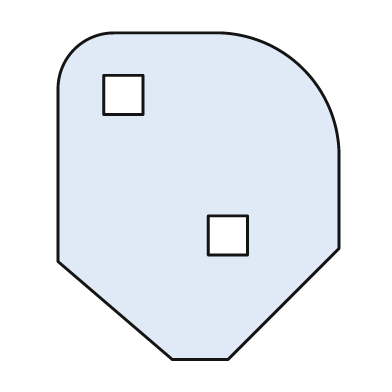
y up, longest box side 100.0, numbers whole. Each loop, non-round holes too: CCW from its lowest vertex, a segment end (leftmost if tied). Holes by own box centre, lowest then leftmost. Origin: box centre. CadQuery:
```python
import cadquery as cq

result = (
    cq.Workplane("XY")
    .moveTo(-8.0, -50.0)
    .lineTo(9.0, -50.0)
    .lineTo(43.0, -16.0)
    .lineTo(43.0, 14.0)
    .threePointArc((32.0, 39.0), (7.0, 50.0))
    .lineTo(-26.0, 50.0)
    .threePointArc((-38.0, 45.0), (-43.0, 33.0))
    .lineTo(-43.0, -20.0)
    .close()
    .moveTo(3.0, -18.0)
    .lineTo(15.0, -18.0)
    .lineTo(15.0, -6.0)
    .lineTo(3.0, -6.0)
    .close()
    .moveTo(-29.0, 25.0)
    .lineTo(-17.0, 25.0)
    .lineTo(-17.0, 37.0)
    .lineTo(-29.0, 37.0)
    .close()
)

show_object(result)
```